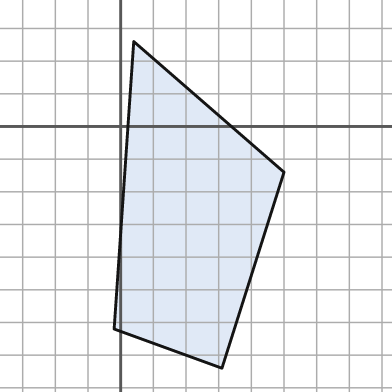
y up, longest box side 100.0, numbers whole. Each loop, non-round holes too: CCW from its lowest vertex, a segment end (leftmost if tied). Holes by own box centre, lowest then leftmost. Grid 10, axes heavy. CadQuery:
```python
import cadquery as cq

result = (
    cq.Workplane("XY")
    .moveTo(31.0, -74.0)
    .lineTo(50.0, -14.0)
    .lineTo(4.0, 26.0)
    .lineTo(-2.0, -62.0)
    .close()
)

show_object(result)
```